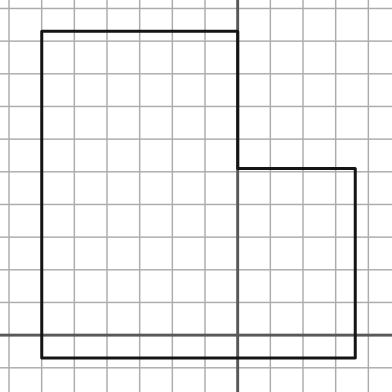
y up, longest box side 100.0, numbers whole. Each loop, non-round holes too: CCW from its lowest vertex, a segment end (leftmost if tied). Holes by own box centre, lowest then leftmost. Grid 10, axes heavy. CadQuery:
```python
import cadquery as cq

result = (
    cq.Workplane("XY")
    .moveTo(-60.0, -7.0)
    .lineTo(36.0, -7.0)
    .lineTo(36.0, 51.0)
    .lineTo(0.0, 51.0)
    .lineTo(0.0, 93.0)
    .lineTo(-60.0, 93.0)
    .close()
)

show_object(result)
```